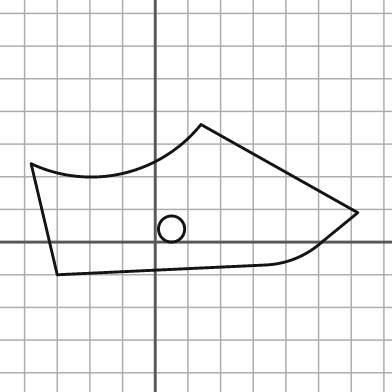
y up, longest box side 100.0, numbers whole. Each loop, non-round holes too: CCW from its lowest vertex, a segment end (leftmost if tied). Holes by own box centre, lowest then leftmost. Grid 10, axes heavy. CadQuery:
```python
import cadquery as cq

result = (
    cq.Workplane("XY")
    .moveTo(-30.0, -10.0)
    .lineTo(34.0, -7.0)
    .threePointArc((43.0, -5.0), (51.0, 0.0))
    .lineTo(62.0, 9.0)
    .lineTo(14.0, 36.0)
    .threePointArc((-10.0, 21.0), (-38.0, 24.0))
    .close()
    .moveTo(5.0, 4.0)
    .circle(4.0)
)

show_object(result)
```